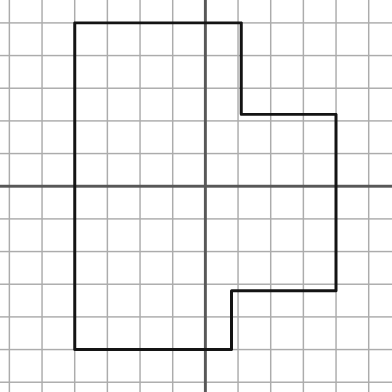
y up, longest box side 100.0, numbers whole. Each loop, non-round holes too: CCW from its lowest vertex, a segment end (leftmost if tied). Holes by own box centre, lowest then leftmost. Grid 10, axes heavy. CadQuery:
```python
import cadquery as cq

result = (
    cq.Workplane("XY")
    .moveTo(-40.0, -50.0)
    .lineTo(8.0, -50.0)
    .lineTo(8.0, -32.0)
    .lineTo(40.0, -32.0)
    .lineTo(40.0, 22.0)
    .lineTo(11.0, 22.0)
    .lineTo(11.0, 50.0)
    .lineTo(-40.0, 50.0)
    .close()
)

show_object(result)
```